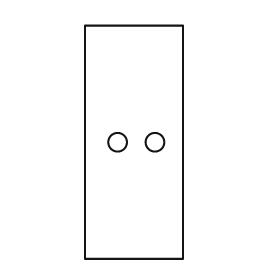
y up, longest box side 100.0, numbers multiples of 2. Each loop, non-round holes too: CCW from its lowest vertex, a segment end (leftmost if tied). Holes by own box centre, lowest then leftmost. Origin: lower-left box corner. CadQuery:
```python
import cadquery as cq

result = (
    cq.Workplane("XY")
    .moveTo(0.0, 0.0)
    .lineTo(42.0, 0.0)
    .lineTo(42.0, 100.0)
    .lineTo(0.0, 100.0)
    .close()
    .moveTo(14.0, 50.0)
    .circle(4.0)
    .moveTo(30.0, 50.0)
    .circle(4.0)
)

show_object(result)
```